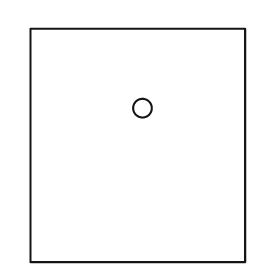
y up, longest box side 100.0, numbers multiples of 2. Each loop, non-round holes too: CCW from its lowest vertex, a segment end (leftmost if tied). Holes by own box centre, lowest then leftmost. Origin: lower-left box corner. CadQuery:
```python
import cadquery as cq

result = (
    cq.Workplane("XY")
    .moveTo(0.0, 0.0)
    .lineTo(92.0, 0.0)
    .lineTo(92.0, 100.0)
    .lineTo(0.0, 100.0)
    .close()
    .moveTo(48.0, 66.0)
    .circle(4.0)
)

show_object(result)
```